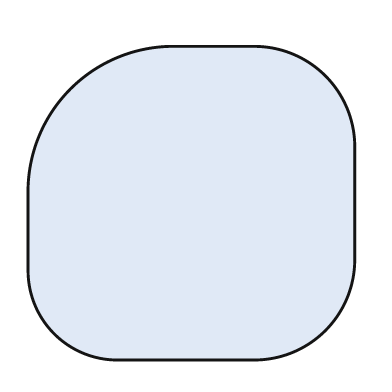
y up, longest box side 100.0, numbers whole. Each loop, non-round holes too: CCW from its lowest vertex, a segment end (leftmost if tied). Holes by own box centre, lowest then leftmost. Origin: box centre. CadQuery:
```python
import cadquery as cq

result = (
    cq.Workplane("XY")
    .moveTo(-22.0, -48.0)
    .lineTo(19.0, -48.0)
    .threePointArc((41.0, -39.0), (50.0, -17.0))
    .lineTo(50.0, 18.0)
    .threePointArc((41.0, 39.0), (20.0, 48.0))
    .lineTo(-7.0, 48.0)
    .threePointArc((-37.0, 35.0), (-50.0, 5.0))
    .lineTo(-50.0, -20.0)
    .threePointArc((-42.0, -40.0), (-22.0, -48.0))
    .close()
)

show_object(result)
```